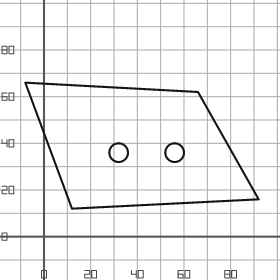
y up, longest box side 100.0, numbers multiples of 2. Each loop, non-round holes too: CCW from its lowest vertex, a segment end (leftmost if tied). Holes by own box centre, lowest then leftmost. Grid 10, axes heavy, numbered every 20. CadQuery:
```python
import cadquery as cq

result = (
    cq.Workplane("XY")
    .moveTo(12.0, 12.0)
    .lineTo(92.0, 16.0)
    .lineTo(66.0, 62.0)
    .lineTo(-8.0, 66.0)
    .close()
    .moveTo(32.0, 36.0)
    .circle(4.0)
    .moveTo(56.0, 36.0)
    .circle(4.0)
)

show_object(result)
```